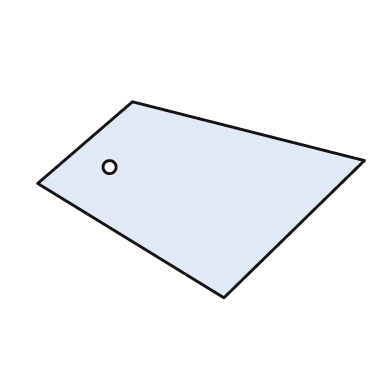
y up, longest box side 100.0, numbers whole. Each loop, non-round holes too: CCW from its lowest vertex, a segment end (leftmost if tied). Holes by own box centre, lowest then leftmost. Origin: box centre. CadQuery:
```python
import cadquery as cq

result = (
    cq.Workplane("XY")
    .moveTo(7.0, -30.0)
    .lineTo(50.0, 12.0)
    .lineTo(-21.0, 30.0)
    .lineTo(-50.0, 5.0)
    .close()
    .moveTo(-28.0, 10.0)
    .circle(2.0)
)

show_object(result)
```